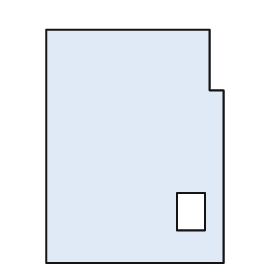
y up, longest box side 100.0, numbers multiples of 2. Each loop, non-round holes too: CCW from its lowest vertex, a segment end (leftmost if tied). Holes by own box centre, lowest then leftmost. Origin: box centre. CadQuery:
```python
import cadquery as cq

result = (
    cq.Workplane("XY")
    .moveTo(-38.0, -50.0)
    .lineTo(38.0, -50.0)
    .lineTo(38.0, 24.0)
    .lineTo(32.0, 24.0)
    .lineTo(32.0, 50.0)
    .lineTo(-38.0, 50.0)
    .close()
    .moveTo(18.0, -36.0)
    .lineTo(30.0, -36.0)
    .lineTo(30.0, -20.0)
    .lineTo(18.0, -20.0)
    .close()
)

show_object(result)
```